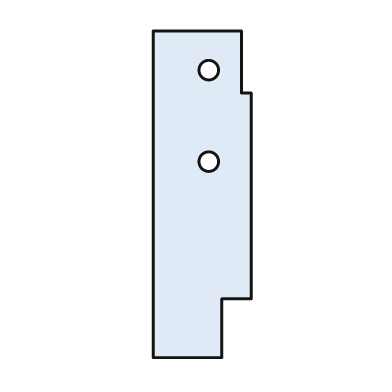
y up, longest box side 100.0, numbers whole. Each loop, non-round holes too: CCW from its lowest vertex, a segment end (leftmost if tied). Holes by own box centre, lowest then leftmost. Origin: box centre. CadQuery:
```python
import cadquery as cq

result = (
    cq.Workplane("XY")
    .moveTo(-15.0, -50.0)
    .lineTo(6.0, -50.0)
    .lineTo(6.0, -32.0)
    .lineTo(15.0, -32.0)
    .lineTo(15.0, 31.0)
    .lineTo(12.0, 31.0)
    .lineTo(12.0, 50.0)
    .lineTo(-15.0, 50.0)
    .close()
    .moveTo(2.0, 10.0)
    .circle(3.0)
    .moveTo(2.0, 38.0)
    .circle(3.0)
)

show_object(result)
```